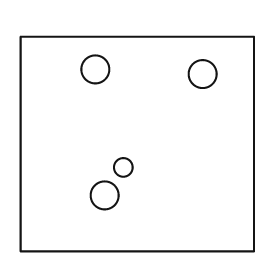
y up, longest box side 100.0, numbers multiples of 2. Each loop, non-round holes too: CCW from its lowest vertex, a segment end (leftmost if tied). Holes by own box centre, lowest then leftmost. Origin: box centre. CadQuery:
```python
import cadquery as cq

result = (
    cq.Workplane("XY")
    .moveTo(-50.0, -46.0)
    .lineTo(50.0, -46.0)
    .lineTo(50.0, 46.0)
    .lineTo(-50.0, 46.0)
    .close()
    .moveTo(-14.0, -22.0)
    .circle(6.0)
    .moveTo(-6.0, -10.0)
    .circle(4.0)
    .moveTo(28.0, 30.0)
    .circle(6.0)
    .moveTo(-18.0, 32.0)
    .circle(6.0)
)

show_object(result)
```